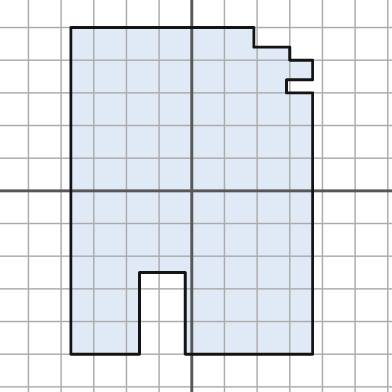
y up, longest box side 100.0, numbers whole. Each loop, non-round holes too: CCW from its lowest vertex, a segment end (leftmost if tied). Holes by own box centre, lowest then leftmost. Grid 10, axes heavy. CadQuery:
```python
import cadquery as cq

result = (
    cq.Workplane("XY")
    .moveTo(-37.0, -50.0)
    .lineTo(-16.0, -50.0)
    .lineTo(-16.0, -25.0)
    .lineTo(-2.0, -25.0)
    .lineTo(-2.0, -50.0)
    .lineTo(37.0, -50.0)
    .lineTo(37.0, 30.0)
    .lineTo(29.0, 30.0)
    .lineTo(29.0, 34.0)
    .lineTo(37.0, 34.0)
    .lineTo(37.0, 40.0)
    .lineTo(30.0, 40.0)
    .lineTo(30.0, 44.0)
    .lineTo(19.0, 44.0)
    .lineTo(19.0, 50.0)
    .lineTo(-37.0, 50.0)
    .close()
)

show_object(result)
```